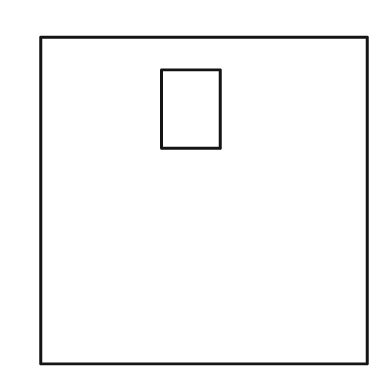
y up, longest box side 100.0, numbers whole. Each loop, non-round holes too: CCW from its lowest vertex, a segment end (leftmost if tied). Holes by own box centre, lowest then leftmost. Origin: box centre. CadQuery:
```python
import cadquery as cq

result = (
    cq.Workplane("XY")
    .moveTo(-50.0, -50.0)
    .lineTo(50.0, -50.0)
    .lineTo(50.0, 50.0)
    .lineTo(-50.0, 50.0)
    .close()
    .moveTo(-13.0, 16.0)
    .lineTo(5.0, 16.0)
    .lineTo(5.0, 40.0)
    .lineTo(-13.0, 40.0)
    .close()
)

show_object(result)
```